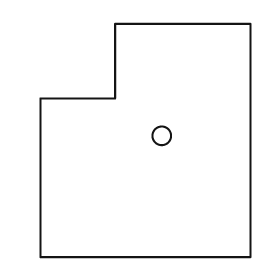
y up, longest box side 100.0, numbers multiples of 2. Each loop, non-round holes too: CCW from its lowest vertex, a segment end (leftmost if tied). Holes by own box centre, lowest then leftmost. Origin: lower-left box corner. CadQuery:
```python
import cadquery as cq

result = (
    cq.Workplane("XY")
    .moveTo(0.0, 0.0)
    .lineTo(90.0, 0.0)
    .lineTo(90.0, 100.0)
    .lineTo(32.0, 100.0)
    .lineTo(32.0, 68.0)
    .lineTo(0.0, 68.0)
    .close()
    .moveTo(52.0, 52.0)
    .circle(4.0)
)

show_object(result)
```